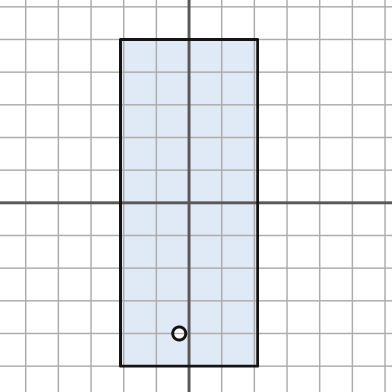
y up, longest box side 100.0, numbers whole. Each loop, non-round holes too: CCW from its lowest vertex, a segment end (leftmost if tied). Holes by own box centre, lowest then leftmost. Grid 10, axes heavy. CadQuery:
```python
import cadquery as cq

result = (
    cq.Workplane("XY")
    .moveTo(-21.0, -50.0)
    .lineTo(21.0, -50.0)
    .lineTo(21.0, 50.0)
    .lineTo(-21.0, 50.0)
    .close()
    .moveTo(-3.0, -40.0)
    .circle(2.0)
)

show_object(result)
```